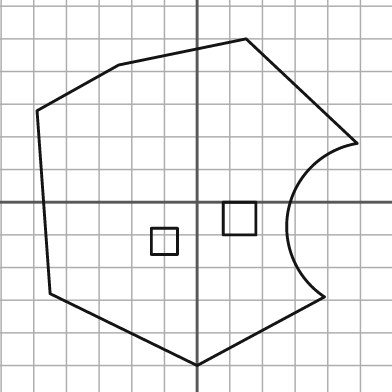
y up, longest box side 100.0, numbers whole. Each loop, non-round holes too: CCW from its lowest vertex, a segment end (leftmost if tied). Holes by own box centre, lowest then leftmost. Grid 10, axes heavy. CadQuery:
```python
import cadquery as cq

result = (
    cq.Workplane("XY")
    .moveTo(0.0, -50.0)
    .lineTo(39.0, -29.0)
    .threePointArc((28.0, -2.0), (49.0, 18.0))
    .lineTo(15.0, 50.0)
    .lineTo(-24.0, 42.0)
    .lineTo(-49.0, 28.0)
    .lineTo(-45.0, -28.0)
    .close()
    .moveTo(-14.0, -16.0)
    .lineTo(-6.0, -16.0)
    .lineTo(-6.0, -8.0)
    .lineTo(-14.0, -8.0)
    .close()
    .moveTo(8.0, -10.0)
    .lineTo(18.0, -10.0)
    .lineTo(18.0, 0.0)
    .lineTo(8.0, 0.0)
    .close()
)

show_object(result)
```